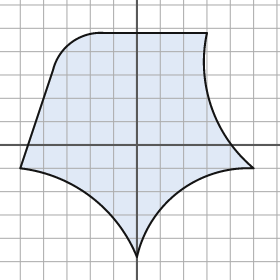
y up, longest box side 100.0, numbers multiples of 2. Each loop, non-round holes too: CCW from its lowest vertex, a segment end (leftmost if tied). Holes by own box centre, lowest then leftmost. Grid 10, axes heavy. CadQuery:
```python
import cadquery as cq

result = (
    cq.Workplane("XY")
    .moveTo(0.0, -48.0)
    .threePointArc((18.0, -20.0), (50.0, -10.0))
    .threePointArc((32.0, 16.0), (30.0, 48.0))
    .lineTo(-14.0, 48.0)
    .threePointArc((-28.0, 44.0), (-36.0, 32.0))
    .lineTo(-50.0, -10.0)
    .threePointArc((-20.0, -22.0), (0.0, -48.0))
    .close()
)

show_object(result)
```